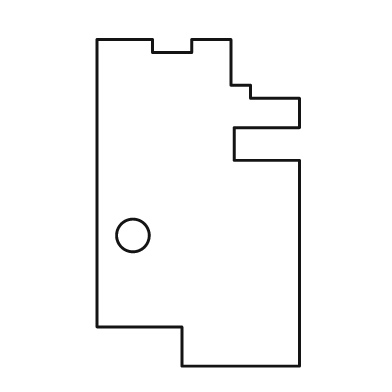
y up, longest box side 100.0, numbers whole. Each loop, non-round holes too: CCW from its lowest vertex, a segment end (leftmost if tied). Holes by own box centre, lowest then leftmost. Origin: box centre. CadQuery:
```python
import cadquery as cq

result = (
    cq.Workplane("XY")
    .moveTo(-5.0, -50.0)
    .lineTo(31.0, -50.0)
    .lineTo(31.0, 13.0)
    .lineTo(11.0, 13.0)
    .lineTo(11.0, 23.0)
    .lineTo(31.0, 23.0)
    .lineTo(31.0, 32.0)
    .lineTo(16.0, 32.0)
    .lineTo(16.0, 36.0)
    .lineTo(10.0, 36.0)
    .lineTo(10.0, 50.0)
    .lineTo(-2.0, 50.0)
    .lineTo(-2.0, 46.0)
    .lineTo(-14.0, 46.0)
    .lineTo(-14.0, 50.0)
    .lineTo(-31.0, 50.0)
    .lineTo(-31.0, -38.0)
    .lineTo(-5.0, -38.0)
    .close()
    .moveTo(-20.0, -10.0)
    .circle(5.0)
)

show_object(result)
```